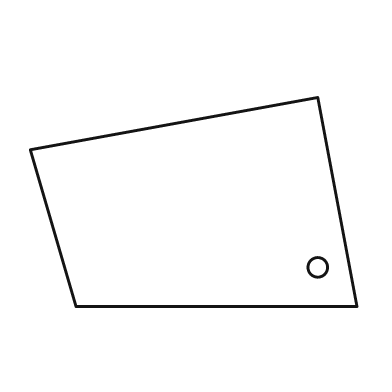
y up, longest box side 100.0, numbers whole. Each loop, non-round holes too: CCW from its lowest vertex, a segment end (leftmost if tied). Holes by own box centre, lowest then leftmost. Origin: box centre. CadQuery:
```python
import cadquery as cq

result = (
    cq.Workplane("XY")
    .moveTo(-36.0, -32.0)
    .lineTo(50.0, -32.0)
    .lineTo(38.0, 32.0)
    .lineTo(-50.0, 16.0)
    .close()
    .moveTo(38.0, -20.0)
    .circle(3.0)
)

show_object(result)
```